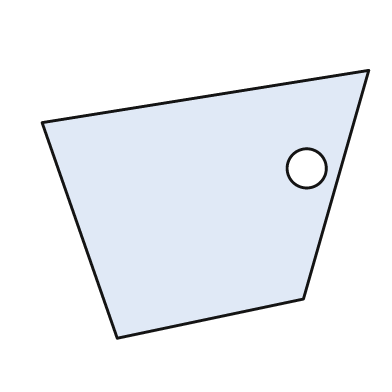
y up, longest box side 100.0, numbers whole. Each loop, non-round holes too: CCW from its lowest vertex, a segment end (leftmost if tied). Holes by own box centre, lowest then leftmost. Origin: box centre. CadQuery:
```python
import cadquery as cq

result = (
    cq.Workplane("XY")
    .moveTo(-27.0, -41.0)
    .lineTo(30.0, -29.0)
    .lineTo(50.0, 41.0)
    .lineTo(-50.0, 25.0)
    .close()
    .moveTo(31.0, 11.0)
    .circle(6.0)
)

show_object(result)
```